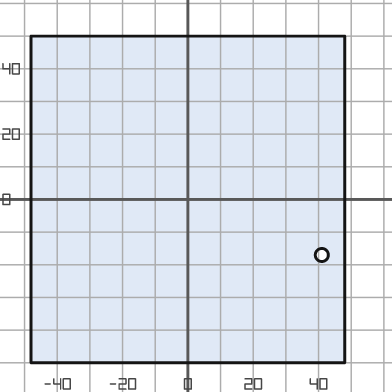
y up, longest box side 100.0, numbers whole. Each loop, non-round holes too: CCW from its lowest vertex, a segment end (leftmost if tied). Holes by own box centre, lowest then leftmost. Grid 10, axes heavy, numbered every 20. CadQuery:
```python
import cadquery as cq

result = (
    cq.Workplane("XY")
    .moveTo(-48.0, -50.0)
    .lineTo(48.0, -50.0)
    .lineTo(48.0, 50.0)
    .lineTo(-48.0, 50.0)
    .close()
    .moveTo(41.0, -17.0)
    .circle(2.0)
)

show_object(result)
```